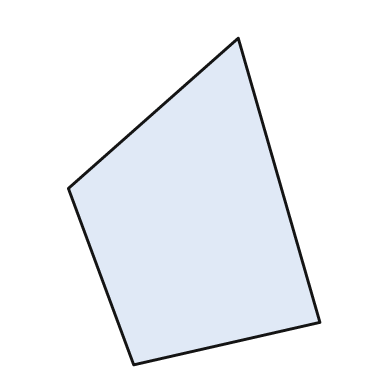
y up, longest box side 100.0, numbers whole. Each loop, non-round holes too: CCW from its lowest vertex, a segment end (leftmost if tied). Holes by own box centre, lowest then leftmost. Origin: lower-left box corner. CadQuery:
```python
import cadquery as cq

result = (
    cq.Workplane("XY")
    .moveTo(20.0, 0.0)
    .lineTo(77.0, 13.0)
    .lineTo(52.0, 100.0)
    .lineTo(0.0, 54.0)
    .close()
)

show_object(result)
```